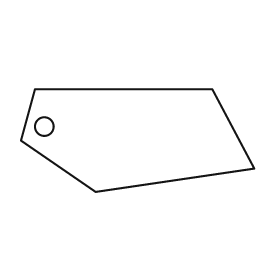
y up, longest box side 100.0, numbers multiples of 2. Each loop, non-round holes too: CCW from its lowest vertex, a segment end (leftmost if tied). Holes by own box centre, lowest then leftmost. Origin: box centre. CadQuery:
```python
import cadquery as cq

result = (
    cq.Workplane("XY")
    .moveTo(-18.0, -22.0)
    .lineTo(50.0, -12.0)
    .lineTo(32.0, 22.0)
    .lineTo(-44.0, 22.0)
    .lineTo(-50.0, 0.0)
    .close()
    .moveTo(-40.0, 6.0)
    .circle(4.0)
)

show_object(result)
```